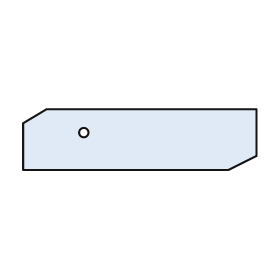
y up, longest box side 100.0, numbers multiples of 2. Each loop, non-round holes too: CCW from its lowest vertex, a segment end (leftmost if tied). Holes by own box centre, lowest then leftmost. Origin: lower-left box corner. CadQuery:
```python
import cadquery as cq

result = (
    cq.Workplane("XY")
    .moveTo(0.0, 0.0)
    .lineTo(88.0, 0.0)
    .lineTo(100.0, 6.0)
    .lineTo(100.0, 26.0)
    .lineTo(10.0, 26.0)
    .lineTo(0.0, 20.0)
    .close()
    .moveTo(26.0, 16.0)
    .circle(2.0)
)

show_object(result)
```